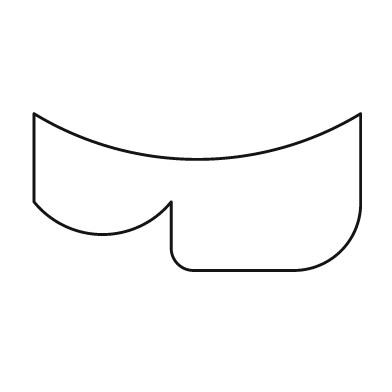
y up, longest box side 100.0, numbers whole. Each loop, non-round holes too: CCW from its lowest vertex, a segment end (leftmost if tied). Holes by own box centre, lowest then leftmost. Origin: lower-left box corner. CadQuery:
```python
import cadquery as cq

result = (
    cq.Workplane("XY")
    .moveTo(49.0, 0.0)
    .lineTo(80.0, 0.0)
    .threePointArc((94.0, 6.0), (100.0, 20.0))
    .lineTo(100.0, 48.0)
    .threePointArc((50.0, 34.0), (0.0, 48.0))
    .lineTo(0.0, 21.0)
    .threePointArc((21.0, 11.0), (42.0, 21.0))
    .lineTo(42.0, 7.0)
    .threePointArc((44.0, 2.0), (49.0, 0.0))
    .close()
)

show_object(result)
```